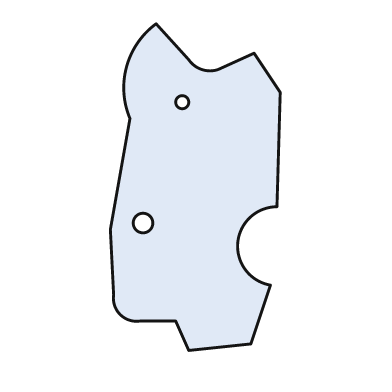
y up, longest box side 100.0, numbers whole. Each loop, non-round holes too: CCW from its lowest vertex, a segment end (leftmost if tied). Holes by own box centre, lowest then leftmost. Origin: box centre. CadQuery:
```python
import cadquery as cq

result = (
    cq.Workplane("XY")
    .moveTo(-2.0, -50.0)
    .lineTo(17.0, -48.0)
    .lineTo(23.0, -30.0)
    .threePointArc((13.0, -17.0), (25.0, -6.0))
    .lineTo(26.0, 29.0)
    .lineTo(18.0, 41.0)
    .lineTo(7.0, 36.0)
    .threePointArc((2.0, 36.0), (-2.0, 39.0))
    .lineTo(-12.0, 50.0)
    .threePointArc((-21.0, 37.0), (-20.0, 21.0))
    .lineTo(-26.0, -13.0)
    .lineTo(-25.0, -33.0)
    .threePointArc((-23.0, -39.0), (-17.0, -41.0))
    .lineTo(-6.0, -41.0)
    .close()
    .moveTo(-16.0, -11.0)
    .circle(3.0)
    .moveTo(-4.0, 26.0)
    .circle(2.0)
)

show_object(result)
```